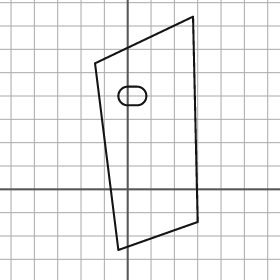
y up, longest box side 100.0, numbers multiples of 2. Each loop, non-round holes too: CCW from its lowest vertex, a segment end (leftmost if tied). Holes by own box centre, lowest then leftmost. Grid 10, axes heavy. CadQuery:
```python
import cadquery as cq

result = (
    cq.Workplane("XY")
    .moveTo(-4.0, -26.0)
    .lineTo(30.0, -14.0)
    .lineTo(28.0, 74.0)
    .lineTo(-14.0, 54.0)
    .close()
    .moveTo(0.0, 36.0)
    .lineTo(4.0, 36.0)
    .threePointArc((8.0, 40.0), (4.0, 44.0))
    .lineTo(0.0, 44.0)
    .threePointArc((-4.0, 40.0), (0.0, 36.0))
    .close()
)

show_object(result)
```